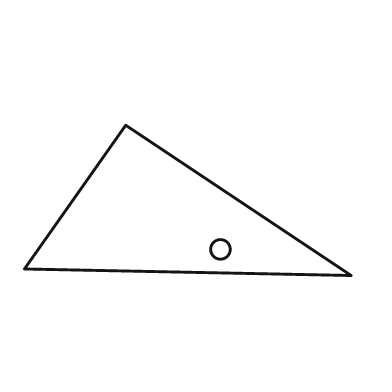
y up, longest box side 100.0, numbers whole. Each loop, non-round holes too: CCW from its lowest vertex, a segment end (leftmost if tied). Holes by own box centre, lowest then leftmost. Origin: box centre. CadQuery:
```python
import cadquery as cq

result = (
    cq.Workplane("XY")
    .moveTo(50.0, -23.0)
    .lineTo(-19.0, 23.0)
    .lineTo(-50.0, -21.0)
    .close()
    .moveTo(10.0, -15.0)
    .circle(3.0)
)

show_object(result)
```